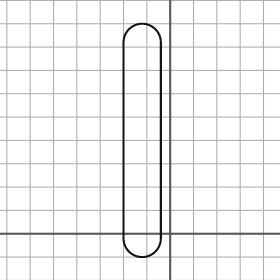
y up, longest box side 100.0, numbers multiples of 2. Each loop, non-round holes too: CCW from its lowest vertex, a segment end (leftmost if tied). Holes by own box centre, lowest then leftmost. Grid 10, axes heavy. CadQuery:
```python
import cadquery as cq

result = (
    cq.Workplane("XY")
    .moveTo(-20.0, -2.0)
    .threePointArc((-12.0, -10.0), (-4.0, -2.0))
    .lineTo(-4.0, 82.0)
    .threePointArc((-12.0, 90.0), (-20.0, 82.0))
    .close()
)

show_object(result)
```